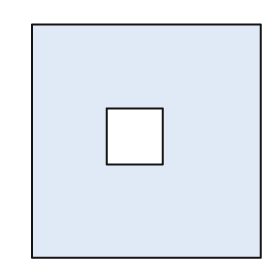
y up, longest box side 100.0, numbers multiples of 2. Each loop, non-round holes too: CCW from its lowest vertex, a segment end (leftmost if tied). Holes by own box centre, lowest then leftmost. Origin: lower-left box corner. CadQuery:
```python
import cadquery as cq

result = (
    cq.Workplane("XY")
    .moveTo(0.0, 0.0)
    .lineTo(98.0, 0.0)
    .lineTo(98.0, 100.0)
    .lineTo(0.0, 100.0)
    .close()
    .moveTo(32.0, 40.0)
    .lineTo(56.0, 40.0)
    .lineTo(56.0, 64.0)
    .lineTo(32.0, 64.0)
    .close()
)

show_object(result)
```